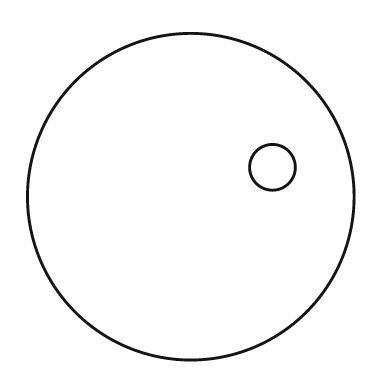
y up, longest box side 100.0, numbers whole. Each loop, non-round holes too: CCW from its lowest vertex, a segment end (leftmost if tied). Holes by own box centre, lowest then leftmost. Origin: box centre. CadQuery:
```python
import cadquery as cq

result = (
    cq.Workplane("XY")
    .moveTo(0.0, 0.0)
    .circle(50.0)
    .moveTo(25.0, 9.0)
    .circle(7.0)
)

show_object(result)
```